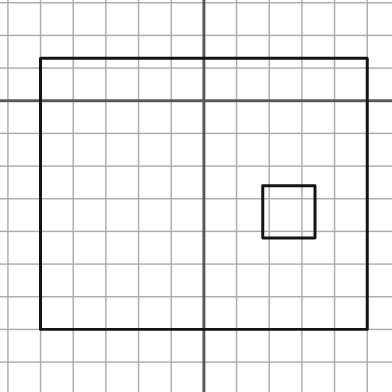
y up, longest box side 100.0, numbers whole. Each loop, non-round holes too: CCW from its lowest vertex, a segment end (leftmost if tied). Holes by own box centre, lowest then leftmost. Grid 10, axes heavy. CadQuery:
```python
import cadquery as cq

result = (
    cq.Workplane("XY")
    .moveTo(-50.0, -70.0)
    .lineTo(50.0, -70.0)
    .lineTo(50.0, 13.0)
    .lineTo(-50.0, 13.0)
    .close()
    .moveTo(18.0, -42.0)
    .lineTo(34.0, -42.0)
    .lineTo(34.0, -26.0)
    .lineTo(18.0, -26.0)
    .close()
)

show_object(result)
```